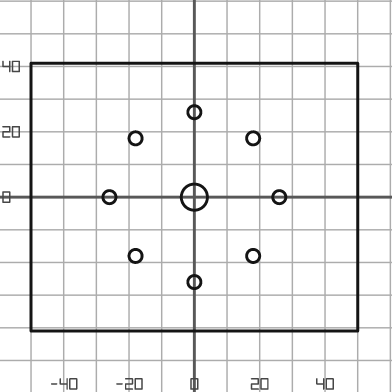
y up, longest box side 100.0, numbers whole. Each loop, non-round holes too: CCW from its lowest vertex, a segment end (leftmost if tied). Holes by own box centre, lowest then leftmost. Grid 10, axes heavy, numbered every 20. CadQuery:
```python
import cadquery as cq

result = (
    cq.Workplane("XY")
    .moveTo(-50.0, -41.0)
    .lineTo(50.0, -41.0)
    .lineTo(50.0, 41.0)
    .lineTo(-50.0, 41.0)
    .close()
    .moveTo(0.0, -26.0)
    .circle(2.0)
    .moveTo(-18.0, -18.0)
    .circle(2.0)
    .moveTo(18.0, -18.0)
    .circle(2.0)
    .moveTo(-26.0, 0.0)
    .circle(2.0)
    .moveTo(0.0, 0.0)
    .circle(4.0)
    .moveTo(26.0, 0.0)
    .circle(2.0)
    .moveTo(-18.0, 18.0)
    .circle(2.0)
    .moveTo(18.0, 18.0)
    .circle(2.0)
    .moveTo(0.0, 26.0)
    .circle(2.0)
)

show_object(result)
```